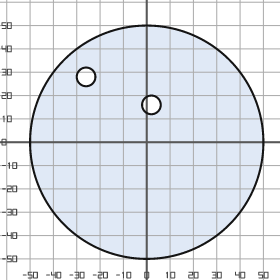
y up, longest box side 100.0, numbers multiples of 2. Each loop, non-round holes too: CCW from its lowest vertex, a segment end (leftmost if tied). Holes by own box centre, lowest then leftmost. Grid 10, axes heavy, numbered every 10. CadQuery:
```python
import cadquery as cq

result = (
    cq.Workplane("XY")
    .moveTo(0.0, 0.0)
    .circle(50.0)
    .moveTo(2.0, 16.0)
    .circle(4.0)
    .moveTo(-26.0, 28.0)
    .circle(4.0)
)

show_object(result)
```